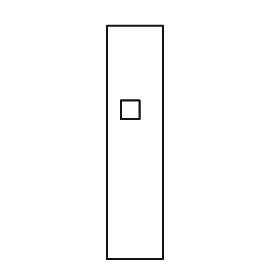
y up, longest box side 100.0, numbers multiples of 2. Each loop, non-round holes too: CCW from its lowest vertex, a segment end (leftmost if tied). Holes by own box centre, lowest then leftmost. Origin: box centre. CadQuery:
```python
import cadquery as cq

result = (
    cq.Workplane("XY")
    .moveTo(-12.0, -50.0)
    .lineTo(12.0, -50.0)
    .lineTo(12.0, 50.0)
    .lineTo(-12.0, 50.0)
    .close()
    .moveTo(-6.0, 10.0)
    .lineTo(2.0, 10.0)
    .lineTo(2.0, 18.0)
    .lineTo(-6.0, 18.0)
    .close()
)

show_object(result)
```